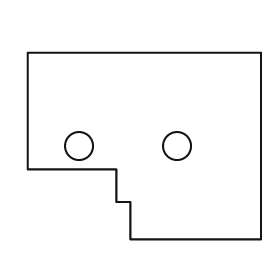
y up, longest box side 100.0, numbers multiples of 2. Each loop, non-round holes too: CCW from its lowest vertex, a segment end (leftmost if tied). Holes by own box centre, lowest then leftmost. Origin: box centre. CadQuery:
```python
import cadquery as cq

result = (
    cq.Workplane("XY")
    .moveTo(-6.0, -40.0)
    .lineTo(50.0, -40.0)
    .lineTo(50.0, 40.0)
    .lineTo(-50.0, 40.0)
    .lineTo(-50.0, -10.0)
    .lineTo(-12.0, -10.0)
    .lineTo(-12.0, -24.0)
    .lineTo(-6.0, -24.0)
    .close()
    .moveTo(-28.0, 0.0)
    .circle(6.0)
    .moveTo(14.0, 0.0)
    .circle(6.0)
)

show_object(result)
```